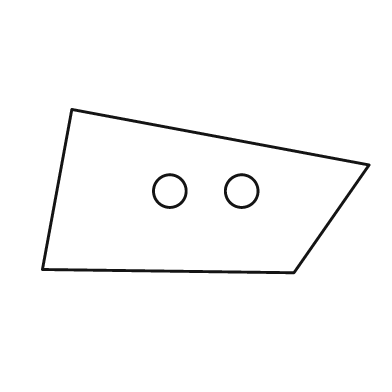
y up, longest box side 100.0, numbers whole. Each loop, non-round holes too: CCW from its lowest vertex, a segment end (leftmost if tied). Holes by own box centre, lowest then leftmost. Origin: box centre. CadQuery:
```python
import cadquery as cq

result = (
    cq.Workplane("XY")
    .moveTo(27.0, -25.0)
    .lineTo(50.0, 8.0)
    .lineTo(-41.0, 25.0)
    .lineTo(-50.0, -24.0)
    .close()
    .moveTo(-11.0, 0.0)
    .circle(5.0)
    .moveTo(11.0, 0.0)
    .circle(5.0)
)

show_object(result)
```